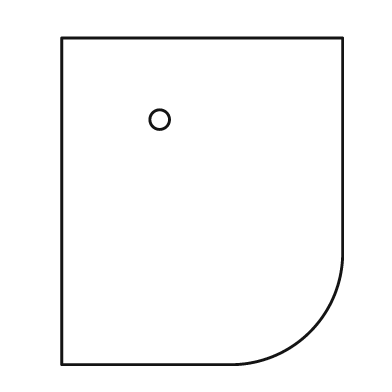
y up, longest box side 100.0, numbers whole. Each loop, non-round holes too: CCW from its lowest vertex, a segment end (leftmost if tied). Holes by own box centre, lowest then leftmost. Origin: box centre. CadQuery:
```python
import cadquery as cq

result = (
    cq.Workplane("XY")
    .moveTo(-43.0, -50.0)
    .lineTo(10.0, -50.0)
    .threePointArc((33.0, -40.0), (43.0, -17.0))
    .lineTo(43.0, 50.0)
    .lineTo(-43.0, 50.0)
    .close()
    .moveTo(-13.0, 25.0)
    .circle(3.0)
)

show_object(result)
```